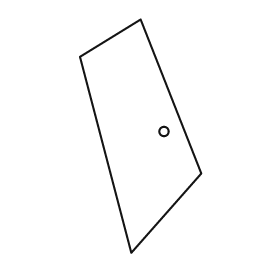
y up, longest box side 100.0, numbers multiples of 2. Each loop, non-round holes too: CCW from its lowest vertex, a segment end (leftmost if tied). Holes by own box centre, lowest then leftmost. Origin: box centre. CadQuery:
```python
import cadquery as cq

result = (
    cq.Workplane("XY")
    .moveTo(-4.0, -50.0)
    .lineTo(26.0, -16.0)
    .lineTo(0.0, 50.0)
    .lineTo(-26.0, 34.0)
    .close()
    .moveTo(10.0, 2.0)
    .circle(2.0)
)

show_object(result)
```